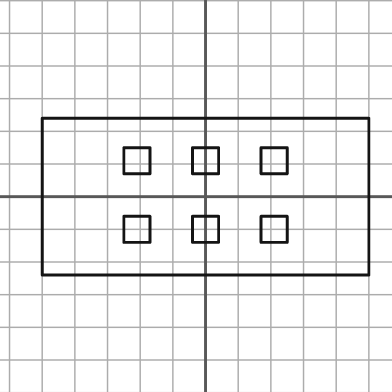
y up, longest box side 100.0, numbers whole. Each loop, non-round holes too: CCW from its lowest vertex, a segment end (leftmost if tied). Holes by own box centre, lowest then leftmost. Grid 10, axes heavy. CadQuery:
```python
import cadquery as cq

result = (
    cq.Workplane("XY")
    .moveTo(-50.0, -24.0)
    .lineTo(50.0, -24.0)
    .lineTo(50.0, 24.0)
    .lineTo(-50.0, 24.0)
    .close()
    .moveTo(-25.0, -14.0)
    .lineTo(-17.0, -14.0)
    .lineTo(-17.0, -6.0)
    .lineTo(-25.0, -6.0)
    .close()
    .moveTo(-4.0, -14.0)
    .lineTo(4.0, -14.0)
    .lineTo(4.0, -6.0)
    .lineTo(-4.0, -6.0)
    .close()
    .moveTo(17.0, -14.0)
    .lineTo(25.0, -14.0)
    .lineTo(25.0, -6.0)
    .lineTo(17.0, -6.0)
    .close()
    .moveTo(-25.0, 7.0)
    .lineTo(-17.0, 7.0)
    .lineTo(-17.0, 15.0)
    .lineTo(-25.0, 15.0)
    .close()
    .moveTo(-4.0, 7.0)
    .lineTo(4.0, 7.0)
    .lineTo(4.0, 15.0)
    .lineTo(-4.0, 15.0)
    .close()
    .moveTo(17.0, 7.0)
    .lineTo(25.0, 7.0)
    .lineTo(25.0, 15.0)
    .lineTo(17.0, 15.0)
    .close()
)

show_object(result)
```